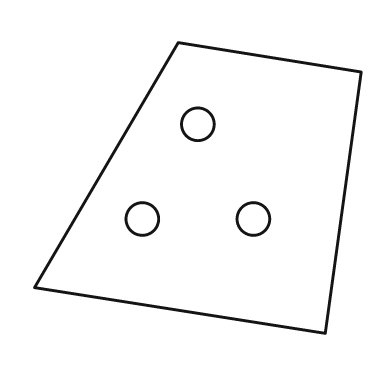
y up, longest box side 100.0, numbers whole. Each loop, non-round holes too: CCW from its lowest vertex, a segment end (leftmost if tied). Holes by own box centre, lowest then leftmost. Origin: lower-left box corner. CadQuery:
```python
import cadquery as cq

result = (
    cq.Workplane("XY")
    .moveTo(89.0, 0.0)
    .lineTo(100.0, 80.0)
    .lineTo(44.0, 89.0)
    .lineTo(0.0, 14.0)
    .close()
    .moveTo(33.0, 35.0)
    .circle(5.0)
    .moveTo(67.0, 35.0)
    .circle(5.0)
    .moveTo(50.0, 64.0)
    .circle(5.0)
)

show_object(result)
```